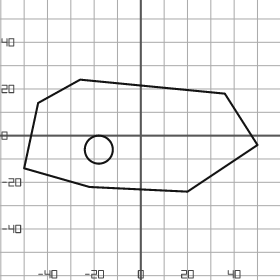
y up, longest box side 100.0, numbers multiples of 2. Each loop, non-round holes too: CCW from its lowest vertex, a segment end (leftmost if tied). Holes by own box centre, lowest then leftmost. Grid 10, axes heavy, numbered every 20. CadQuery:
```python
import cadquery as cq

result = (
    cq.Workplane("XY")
    .moveTo(20.0, -24.0)
    .lineTo(50.0, -4.0)
    .lineTo(36.0, 18.0)
    .lineTo(-26.0, 24.0)
    .lineTo(-44.0, 14.0)
    .lineTo(-50.0, -14.0)
    .lineTo(-22.0, -22.0)
    .close()
    .moveTo(-18.0, -6.0)
    .circle(6.0)
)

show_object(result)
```